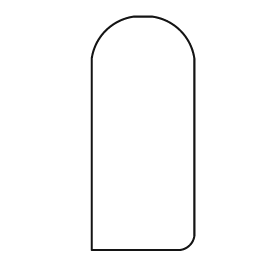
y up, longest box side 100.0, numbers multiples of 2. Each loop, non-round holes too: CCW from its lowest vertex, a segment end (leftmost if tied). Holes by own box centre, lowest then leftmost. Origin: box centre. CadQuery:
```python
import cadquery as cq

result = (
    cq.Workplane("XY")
    .moveTo(-22.0, -50.0)
    .lineTo(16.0, -50.0)
    .threePointArc((20.0, -48.0), (22.0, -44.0))
    .lineTo(22.0, 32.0)
    .threePointArc((16.0, 44.0), (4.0, 50.0))
    .lineTo(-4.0, 50.0)
    .threePointArc((-16.0, 44.0), (-22.0, 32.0))
    .close()
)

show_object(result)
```